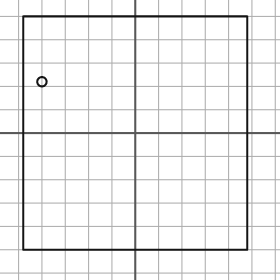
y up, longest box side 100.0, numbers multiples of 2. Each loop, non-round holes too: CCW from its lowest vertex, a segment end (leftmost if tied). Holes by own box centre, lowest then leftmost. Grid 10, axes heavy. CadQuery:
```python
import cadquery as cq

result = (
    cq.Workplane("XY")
    .moveTo(-48.0, -50.0)
    .lineTo(48.0, -50.0)
    .lineTo(48.0, 50.0)
    .lineTo(-48.0, 50.0)
    .close()
    .moveTo(-40.0, 22.0)
    .circle(2.0)
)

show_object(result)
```